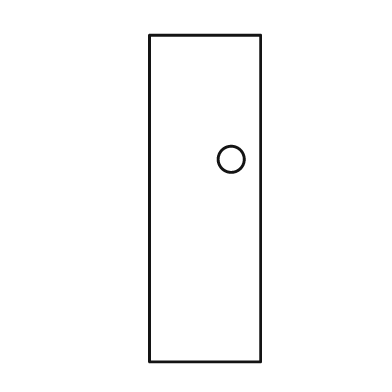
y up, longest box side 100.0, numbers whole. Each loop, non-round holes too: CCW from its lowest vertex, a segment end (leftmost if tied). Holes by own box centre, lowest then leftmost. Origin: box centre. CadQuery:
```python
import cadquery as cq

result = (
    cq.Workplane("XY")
    .moveTo(-17.0, -50.0)
    .lineTo(17.0, -50.0)
    .lineTo(17.0, 50.0)
    .lineTo(-17.0, 50.0)
    .close()
    .moveTo(8.0, 12.0)
    .circle(4.0)
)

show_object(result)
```